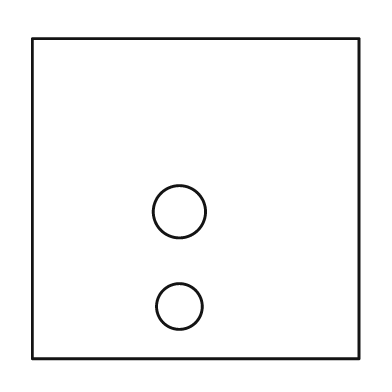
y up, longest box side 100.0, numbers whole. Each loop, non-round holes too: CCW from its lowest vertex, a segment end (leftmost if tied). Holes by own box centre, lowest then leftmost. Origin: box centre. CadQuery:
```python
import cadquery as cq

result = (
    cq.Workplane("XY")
    .moveTo(-50.0, -49.0)
    .lineTo(50.0, -49.0)
    .lineTo(50.0, 49.0)
    .lineTo(-50.0, 49.0)
    .close()
    .moveTo(-5.0, -33.0)
    .circle(7.0)
    .moveTo(-5.0, -4.0)
    .circle(8.0)
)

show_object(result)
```